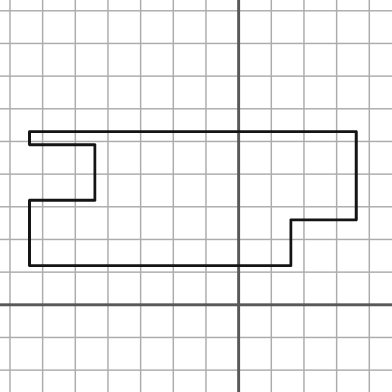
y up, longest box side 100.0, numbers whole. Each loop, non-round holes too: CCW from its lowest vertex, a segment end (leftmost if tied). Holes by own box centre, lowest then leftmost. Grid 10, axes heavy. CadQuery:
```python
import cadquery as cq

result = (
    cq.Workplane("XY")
    .moveTo(-64.0, 12.0)
    .lineTo(16.0, 12.0)
    .lineTo(16.0, 26.0)
    .lineTo(36.0, 26.0)
    .lineTo(36.0, 53.0)
    .lineTo(-64.0, 53.0)
    .lineTo(-64.0, 49.0)
    .lineTo(-44.0, 49.0)
    .lineTo(-44.0, 32.0)
    .lineTo(-64.0, 32.0)
    .close()
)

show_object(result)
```